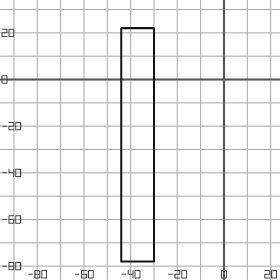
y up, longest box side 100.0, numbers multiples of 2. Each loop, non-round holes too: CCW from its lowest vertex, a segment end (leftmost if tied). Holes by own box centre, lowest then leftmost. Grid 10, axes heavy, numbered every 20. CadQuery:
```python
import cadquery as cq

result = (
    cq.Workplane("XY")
    .moveTo(-44.0, -78.0)
    .lineTo(-30.0, -78.0)
    .lineTo(-30.0, 22.0)
    .lineTo(-44.0, 22.0)
    .close()
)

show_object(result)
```